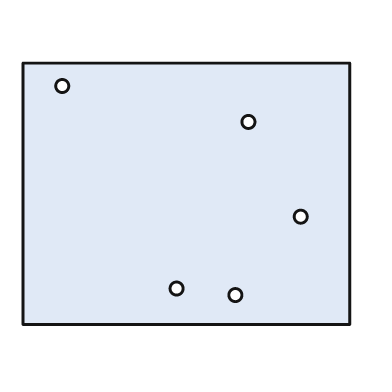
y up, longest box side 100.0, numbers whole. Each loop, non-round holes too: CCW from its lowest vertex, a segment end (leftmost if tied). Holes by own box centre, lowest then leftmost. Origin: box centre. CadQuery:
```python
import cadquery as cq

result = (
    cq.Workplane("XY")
    .moveTo(-50.0, -40.0)
    .lineTo(50.0, -40.0)
    .lineTo(50.0, 40.0)
    .lineTo(-50.0, 40.0)
    .close()
    .moveTo(15.0, -31.0)
    .circle(2.0)
    .moveTo(-3.0, -29.0)
    .circle(2.0)
    .moveTo(35.0, -7.0)
    .circle(2.0)
    .moveTo(19.0, 22.0)
    .circle(2.0)
    .moveTo(-38.0, 33.0)
    .circle(2.0)
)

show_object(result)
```